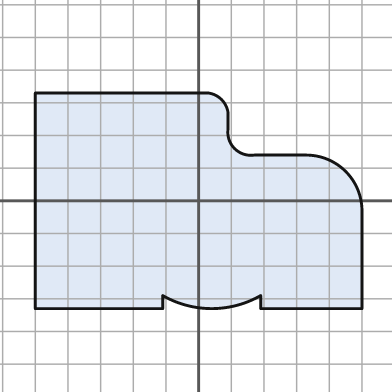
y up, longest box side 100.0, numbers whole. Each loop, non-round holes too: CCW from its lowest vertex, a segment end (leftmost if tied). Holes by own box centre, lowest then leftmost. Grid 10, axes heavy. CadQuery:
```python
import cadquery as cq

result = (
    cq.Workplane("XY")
    .moveTo(-50.0, -33.0)
    .lineTo(-11.0, -33.0)
    .lineTo(-11.0, -29.0)
    .threePointArc((4.0, -33.0), (19.0, -29.0))
    .lineTo(19.0, -33.0)
    .lineTo(50.0, -33.0)
    .lineTo(50.0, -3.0)
    .threePointArc((45.0, 9.0), (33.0, 14.0))
    .lineTo(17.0, 14.0)
    .threePointArc((11.0, 16.0), (9.0, 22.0))
    .lineTo(9.0, 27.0)
    .threePointArc((7.0, 31.0), (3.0, 33.0))
    .lineTo(-50.0, 33.0)
    .close()
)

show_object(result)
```